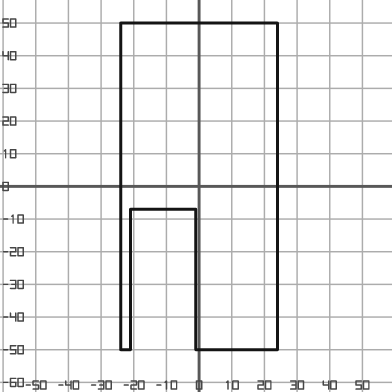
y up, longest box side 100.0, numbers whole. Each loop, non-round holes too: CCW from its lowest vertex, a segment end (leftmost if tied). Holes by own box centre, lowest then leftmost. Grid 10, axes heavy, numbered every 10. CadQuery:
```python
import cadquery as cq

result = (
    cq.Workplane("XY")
    .moveTo(-24.0, -50.0)
    .lineTo(-21.0, -50.0)
    .lineTo(-21.0, -7.0)
    .lineTo(-1.0, -7.0)
    .lineTo(-1.0, -50.0)
    .lineTo(24.0, -50.0)
    .lineTo(24.0, 50.0)
    .lineTo(-24.0, 50.0)
    .close()
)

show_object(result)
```